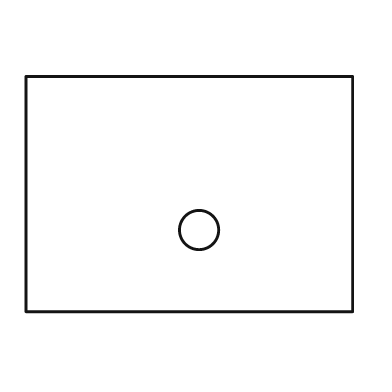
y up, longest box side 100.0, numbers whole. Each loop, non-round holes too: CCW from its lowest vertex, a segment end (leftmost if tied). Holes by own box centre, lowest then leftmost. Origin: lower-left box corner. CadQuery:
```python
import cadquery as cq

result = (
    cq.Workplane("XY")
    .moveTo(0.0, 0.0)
    .lineTo(100.0, 0.0)
    .lineTo(100.0, 72.0)
    .lineTo(0.0, 72.0)
    .close()
    .moveTo(53.0, 25.0)
    .circle(6.0)
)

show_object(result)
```